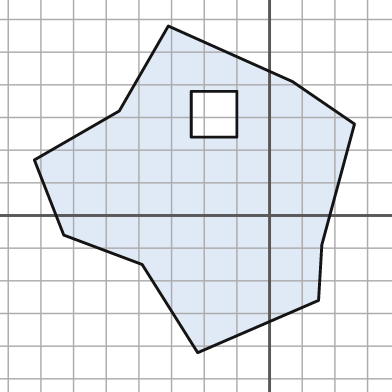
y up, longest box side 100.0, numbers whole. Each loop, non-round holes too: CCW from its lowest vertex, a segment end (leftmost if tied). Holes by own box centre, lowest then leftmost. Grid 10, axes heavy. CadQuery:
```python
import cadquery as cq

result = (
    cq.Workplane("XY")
    .moveTo(-22.0, -42.0)
    .lineTo(15.0, -26.0)
    .lineTo(16.0, -9.0)
    .lineTo(26.0, 28.0)
    .lineTo(7.0, 41.0)
    .lineTo(-31.0, 58.0)
    .lineTo(-46.0, 32.0)
    .lineTo(-72.0, 17.0)
    .lineTo(-63.0, -6.0)
    .lineTo(-39.0, -15.0)
    .close()
    .moveTo(-24.0, 24.0)
    .lineTo(-10.0, 24.0)
    .lineTo(-10.0, 38.0)
    .lineTo(-24.0, 38.0)
    .close()
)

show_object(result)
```